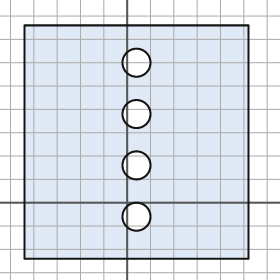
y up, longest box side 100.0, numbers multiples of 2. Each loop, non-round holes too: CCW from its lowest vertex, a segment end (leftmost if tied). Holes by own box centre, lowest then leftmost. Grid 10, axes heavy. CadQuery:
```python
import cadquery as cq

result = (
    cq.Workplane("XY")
    .moveTo(-44.0, -24.0)
    .lineTo(52.0, -24.0)
    .lineTo(52.0, 76.0)
    .lineTo(-44.0, 76.0)
    .close()
    .moveTo(4.0, -6.0)
    .circle(6.0)
    .moveTo(4.0, 16.0)
    .circle(6.0)
    .moveTo(4.0, 38.0)
    .circle(6.0)
    .moveTo(4.0, 60.0)
    .circle(6.0)
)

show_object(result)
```